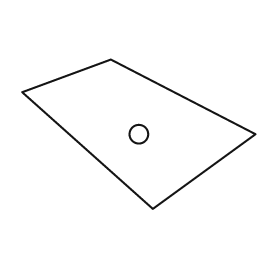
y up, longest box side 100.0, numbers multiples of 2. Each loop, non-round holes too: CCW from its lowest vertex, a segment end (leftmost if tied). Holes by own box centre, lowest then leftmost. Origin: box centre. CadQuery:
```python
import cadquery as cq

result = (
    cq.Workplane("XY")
    .moveTo(6.0, -32.0)
    .lineTo(50.0, 0.0)
    .lineTo(-12.0, 32.0)
    .lineTo(-50.0, 18.0)
    .close()
    .moveTo(0.0, 0.0)
    .circle(4.0)
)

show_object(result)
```